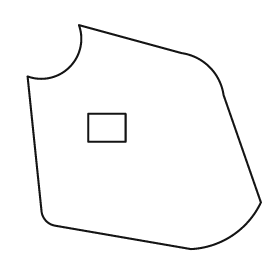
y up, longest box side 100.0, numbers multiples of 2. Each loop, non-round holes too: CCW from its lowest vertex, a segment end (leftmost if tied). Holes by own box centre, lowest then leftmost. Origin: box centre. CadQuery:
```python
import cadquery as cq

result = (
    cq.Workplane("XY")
    .moveTo(20.0, -48.0)
    .threePointArc((38.0, -42.0), (50.0, -28.0))
    .lineTo(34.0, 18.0)
    .threePointArc((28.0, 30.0), (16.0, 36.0))
    .lineTo(-28.0, 48.0)
    .threePointArc((-32.0, 30.0), (-50.0, 26.0))
    .lineTo(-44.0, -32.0)
    .threePointArc((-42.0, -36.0), (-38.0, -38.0))
    .close()
    .moveTo(-24.0, -2.0)
    .lineTo(-8.0, -2.0)
    .lineTo(-8.0, 10.0)
    .lineTo(-24.0, 10.0)
    .close()
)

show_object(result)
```